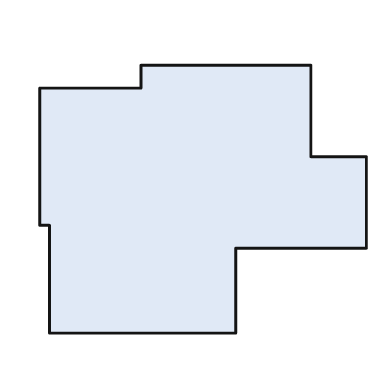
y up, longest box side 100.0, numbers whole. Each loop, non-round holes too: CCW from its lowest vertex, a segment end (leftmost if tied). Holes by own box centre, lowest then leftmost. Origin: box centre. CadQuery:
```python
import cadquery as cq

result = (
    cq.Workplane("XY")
    .moveTo(-47.0, -41.0)
    .lineTo(10.0, -41.0)
    .lineTo(10.0, -15.0)
    .lineTo(50.0, -15.0)
    .lineTo(50.0, 13.0)
    .lineTo(33.0, 13.0)
    .lineTo(33.0, 41.0)
    .lineTo(-19.0, 41.0)
    .lineTo(-19.0, 34.0)
    .lineTo(-50.0, 34.0)
    .lineTo(-50.0, -8.0)
    .lineTo(-47.0, -8.0)
    .close()
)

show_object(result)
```